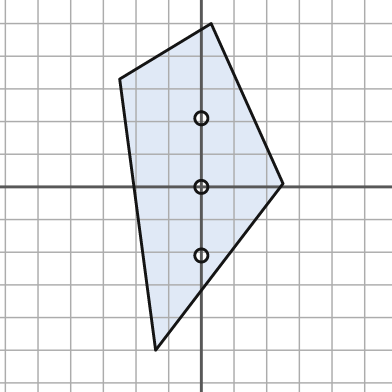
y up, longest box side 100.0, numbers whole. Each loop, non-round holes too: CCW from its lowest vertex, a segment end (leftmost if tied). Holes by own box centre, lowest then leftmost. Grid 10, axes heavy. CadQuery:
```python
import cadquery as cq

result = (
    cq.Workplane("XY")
    .moveTo(-14.0, -50.0)
    .lineTo(25.0, 1.0)
    .lineTo(3.0, 50.0)
    .lineTo(-25.0, 33.0)
    .close()
    .moveTo(0.0, -21.0)
    .circle(2.0)
    .moveTo(0.0, 0.0)
    .circle(2.0)
    .moveTo(0.0, 21.0)
    .circle(2.0)
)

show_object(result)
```